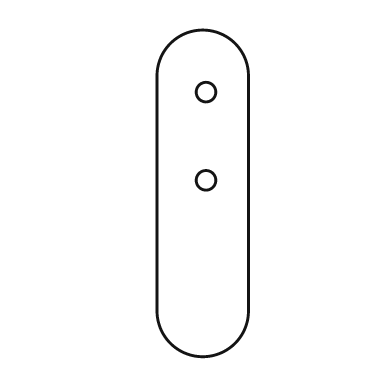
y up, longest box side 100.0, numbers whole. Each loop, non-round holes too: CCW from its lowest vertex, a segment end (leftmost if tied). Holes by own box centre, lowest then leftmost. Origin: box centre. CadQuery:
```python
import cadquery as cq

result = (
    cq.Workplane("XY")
    .moveTo(-14.0, -36.0)
    .threePointArc((0.0, -50.0), (14.0, -36.0))
    .lineTo(14.0, 36.0)
    .threePointArc((0.0, 50.0), (-14.0, 36.0))
    .close()
    .moveTo(1.0, 4.0)
    .circle(3.0)
    .moveTo(1.0, 31.0)
    .circle(3.0)
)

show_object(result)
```